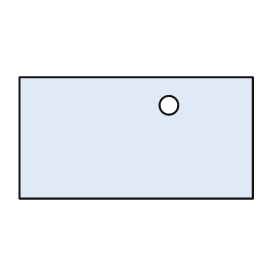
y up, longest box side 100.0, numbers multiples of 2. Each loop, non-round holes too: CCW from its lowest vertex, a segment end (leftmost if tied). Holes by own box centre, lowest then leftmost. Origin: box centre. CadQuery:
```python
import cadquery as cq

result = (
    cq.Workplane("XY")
    .moveTo(-50.0, -26.0)
    .lineTo(50.0, -26.0)
    .lineTo(50.0, 26.0)
    .lineTo(-50.0, 26.0)
    .close()
    .moveTo(14.0, 14.0)
    .circle(4.0)
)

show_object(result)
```